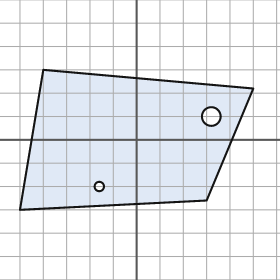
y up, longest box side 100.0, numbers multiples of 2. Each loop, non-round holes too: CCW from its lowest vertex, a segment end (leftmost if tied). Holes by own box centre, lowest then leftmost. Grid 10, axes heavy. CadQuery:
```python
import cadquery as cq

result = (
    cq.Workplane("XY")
    .moveTo(-50.0, -30.0)
    .lineTo(30.0, -26.0)
    .lineTo(50.0, 22.0)
    .lineTo(-40.0, 30.0)
    .close()
    .moveTo(-16.0, -20.0)
    .circle(2.0)
    .moveTo(32.0, 10.0)
    .circle(4.0)
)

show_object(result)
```